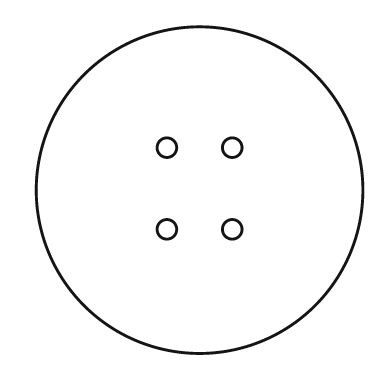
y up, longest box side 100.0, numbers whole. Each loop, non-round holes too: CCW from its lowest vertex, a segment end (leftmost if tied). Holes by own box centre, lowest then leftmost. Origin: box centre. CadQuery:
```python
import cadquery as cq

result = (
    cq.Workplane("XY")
    .moveTo(0.0, 0.0)
    .circle(50.0)
    .moveTo(-10.0, -12.0)
    .circle(3.0)
    .moveTo(10.0, -12.0)
    .circle(3.0)
    .moveTo(-10.0, 13.0)
    .circle(3.0)
    .moveTo(10.0, 13.0)
    .circle(3.0)
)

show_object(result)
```